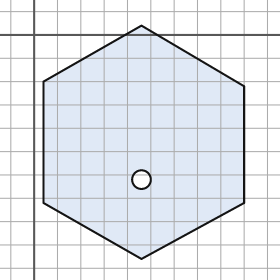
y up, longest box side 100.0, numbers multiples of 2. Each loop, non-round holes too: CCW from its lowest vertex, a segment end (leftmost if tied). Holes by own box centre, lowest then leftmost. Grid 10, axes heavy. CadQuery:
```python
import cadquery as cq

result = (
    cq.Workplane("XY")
    .moveTo(46.0, -96.0)
    .lineTo(90.0, -72.0)
    .lineTo(90.0, -22.0)
    .lineTo(46.0, 4.0)
    .lineTo(4.0, -20.0)
    .lineTo(4.0, -72.0)
    .close()
    .moveTo(46.0, -62.0)
    .circle(4.0)
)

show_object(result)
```